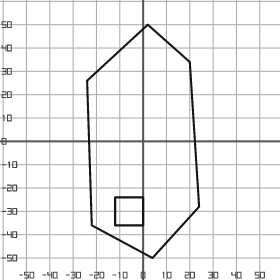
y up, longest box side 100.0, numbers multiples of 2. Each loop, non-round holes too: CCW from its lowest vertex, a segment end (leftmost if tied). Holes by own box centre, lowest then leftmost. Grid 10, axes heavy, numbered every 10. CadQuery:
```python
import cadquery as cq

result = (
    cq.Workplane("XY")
    .moveTo(4.0, -50.0)
    .lineTo(24.0, -28.0)
    .lineTo(20.0, 34.0)
    .lineTo(2.0, 50.0)
    .lineTo(-24.0, 26.0)
    .lineTo(-22.0, -36.0)
    .close()
    .moveTo(-12.0, -36.0)
    .lineTo(0.0, -36.0)
    .lineTo(0.0, -24.0)
    .lineTo(-12.0, -24.0)
    .close()
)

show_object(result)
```